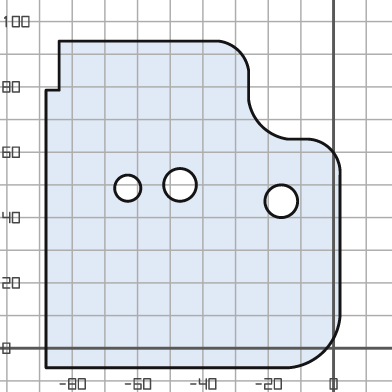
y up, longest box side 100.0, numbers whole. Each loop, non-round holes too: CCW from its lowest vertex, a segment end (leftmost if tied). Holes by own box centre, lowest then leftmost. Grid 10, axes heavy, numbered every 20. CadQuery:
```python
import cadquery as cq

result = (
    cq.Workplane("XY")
    .moveTo(-88.0, -6.0)
    .lineTo(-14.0, -6.0)
    .threePointArc((-3.0, -1.0), (2.0, 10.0))
    .lineTo(2.0, 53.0)
    .threePointArc((-1.0, 61.0), (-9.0, 64.0))
    .lineTo(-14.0, 64.0)
    .threePointArc((-22.0, 68.0), (-26.0, 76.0))
    .lineTo(-26.0, 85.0)
    .threePointArc((-29.0, 91.0), (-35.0, 94.0))
    .lineTo(-84.0, 94.0)
    .lineTo(-84.0, 79.0)
    .lineTo(-88.0, 79.0)
    .close()
    .moveTo(-16.0, 45.0)
    .circle(5.0)
    .moveTo(-63.0, 49.0)
    .circle(4.0)
    .moveTo(-47.0, 50.0)
    .circle(5.0)
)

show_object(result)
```